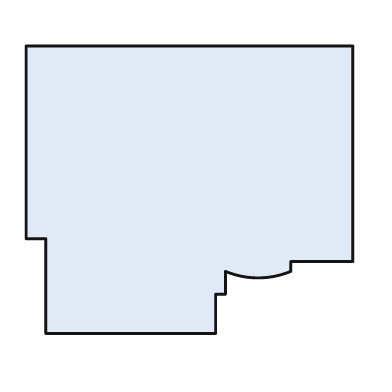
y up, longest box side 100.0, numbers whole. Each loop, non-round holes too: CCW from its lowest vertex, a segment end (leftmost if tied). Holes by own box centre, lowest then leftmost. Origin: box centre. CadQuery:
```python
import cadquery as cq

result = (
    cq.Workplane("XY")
    .moveTo(-44.0, -44.0)
    .lineTo(8.0, -44.0)
    .lineTo(8.0, -32.0)
    .lineTo(11.0, -32.0)
    .lineTo(11.0, -25.0)
    .threePointArc((21.0, -27.0), (31.0, -25.0))
    .lineTo(31.0, -22.0)
    .lineTo(50.0, -22.0)
    .lineTo(50.0, 44.0)
    .lineTo(-50.0, 44.0)
    .lineTo(-50.0, -15.0)
    .lineTo(-44.0, -15.0)
    .close()
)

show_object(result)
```